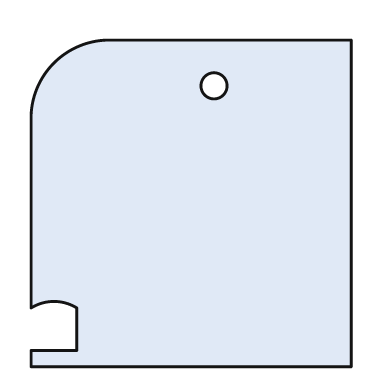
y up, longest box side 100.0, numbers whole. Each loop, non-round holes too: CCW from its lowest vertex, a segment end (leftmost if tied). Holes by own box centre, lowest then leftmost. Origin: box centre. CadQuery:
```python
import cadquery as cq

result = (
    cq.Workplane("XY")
    .moveTo(-49.0, -50.0)
    .lineTo(49.0, -50.0)
    .lineTo(49.0, 50.0)
    .lineTo(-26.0, 50.0)
    .threePointArc((-42.0, 43.0), (-49.0, 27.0))
    .lineTo(-49.0, -32.0)
    .threePointArc((-42.0, -30.0), (-35.0, -32.0))
    .lineTo(-35.0, -45.0)
    .lineTo(-49.0, -45.0)
    .close()
    .moveTo(7.0, 36.0)
    .circle(4.0)
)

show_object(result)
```